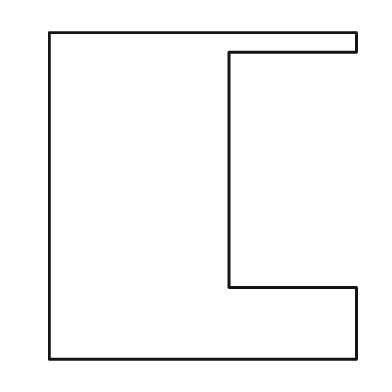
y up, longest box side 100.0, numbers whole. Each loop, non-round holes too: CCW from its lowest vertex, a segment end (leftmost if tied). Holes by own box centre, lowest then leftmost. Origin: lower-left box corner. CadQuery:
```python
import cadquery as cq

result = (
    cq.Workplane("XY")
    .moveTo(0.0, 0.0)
    .lineTo(94.0, 0.0)
    .lineTo(94.0, 22.0)
    .lineTo(55.0, 22.0)
    .lineTo(55.0, 94.0)
    .lineTo(94.0, 94.0)
    .lineTo(94.0, 100.0)
    .lineTo(0.0, 100.0)
    .close()
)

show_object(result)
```